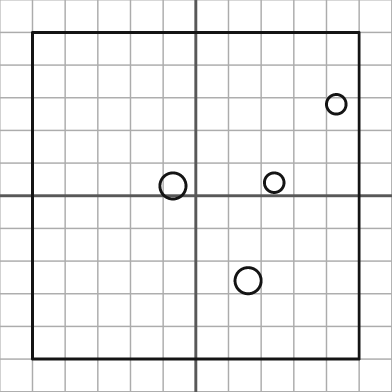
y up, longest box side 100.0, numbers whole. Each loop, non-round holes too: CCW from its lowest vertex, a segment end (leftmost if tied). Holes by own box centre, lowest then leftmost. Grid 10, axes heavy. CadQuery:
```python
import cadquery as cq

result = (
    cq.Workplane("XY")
    .moveTo(-50.0, -50.0)
    .lineTo(50.0, -50.0)
    .lineTo(50.0, 50.0)
    .lineTo(-50.0, 50.0)
    .close()
    .moveTo(16.0, -26.0)
    .circle(4.0)
    .moveTo(-7.0, 3.0)
    .circle(4.0)
    .moveTo(24.0, 4.0)
    .circle(3.0)
    .moveTo(43.0, 28.0)
    .circle(3.0)
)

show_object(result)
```